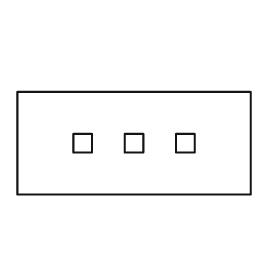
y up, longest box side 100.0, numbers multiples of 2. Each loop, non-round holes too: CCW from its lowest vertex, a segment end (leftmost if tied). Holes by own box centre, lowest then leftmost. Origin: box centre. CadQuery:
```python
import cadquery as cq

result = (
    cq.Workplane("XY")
    .moveTo(-50.0, -22.0)
    .lineTo(50.0, -22.0)
    .lineTo(50.0, 22.0)
    .lineTo(-50.0, 22.0)
    .close()
    .moveTo(-26.0, -4.0)
    .lineTo(-18.0, -4.0)
    .lineTo(-18.0, 4.0)
    .lineTo(-26.0, 4.0)
    .close()
    .moveTo(-4.0, -4.0)
    .lineTo(4.0, -4.0)
    .lineTo(4.0, 4.0)
    .lineTo(-4.0, 4.0)
    .close()
    .moveTo(18.0, -4.0)
    .lineTo(26.0, -4.0)
    .lineTo(26.0, 4.0)
    .lineTo(18.0, 4.0)
    .close()
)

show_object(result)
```